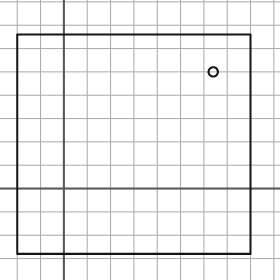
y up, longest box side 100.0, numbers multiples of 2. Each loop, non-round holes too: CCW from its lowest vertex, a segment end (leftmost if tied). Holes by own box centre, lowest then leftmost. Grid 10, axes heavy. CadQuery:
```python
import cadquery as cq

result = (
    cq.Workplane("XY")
    .moveTo(-20.0, -28.0)
    .lineTo(80.0, -28.0)
    .lineTo(80.0, 66.0)
    .lineTo(-20.0, 66.0)
    .close()
    .moveTo(64.0, 50.0)
    .circle(2.0)
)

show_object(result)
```